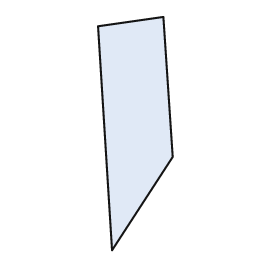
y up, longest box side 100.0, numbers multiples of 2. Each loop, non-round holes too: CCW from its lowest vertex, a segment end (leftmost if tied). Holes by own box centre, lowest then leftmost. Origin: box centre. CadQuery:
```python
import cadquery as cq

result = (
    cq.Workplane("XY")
    .moveTo(-10.0, -50.0)
    .lineTo(16.0, -10.0)
    .lineTo(12.0, 50.0)
    .lineTo(-16.0, 46.0)
    .close()
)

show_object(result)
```